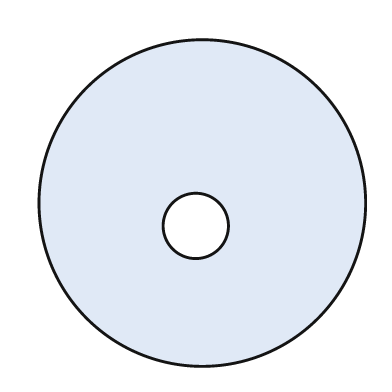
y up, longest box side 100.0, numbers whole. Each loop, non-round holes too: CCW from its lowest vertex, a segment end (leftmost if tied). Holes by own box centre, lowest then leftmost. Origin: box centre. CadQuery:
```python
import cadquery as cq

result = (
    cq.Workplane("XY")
    .moveTo(0.0, 0.0)
    .circle(50.0)
    .moveTo(-2.0, -7.0)
    .circle(10.0)
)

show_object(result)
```